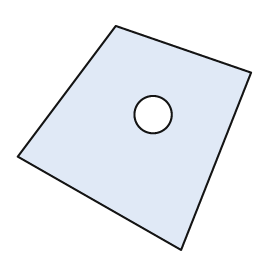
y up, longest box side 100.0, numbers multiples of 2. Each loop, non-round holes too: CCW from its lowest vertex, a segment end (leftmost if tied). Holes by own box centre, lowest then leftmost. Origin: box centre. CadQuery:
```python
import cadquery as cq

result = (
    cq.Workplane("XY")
    .moveTo(20.0, -48.0)
    .lineTo(50.0, 28.0)
    .lineTo(-8.0, 48.0)
    .lineTo(-50.0, -8.0)
    .close()
    .moveTo(8.0, 10.0)
    .circle(8.0)
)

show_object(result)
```